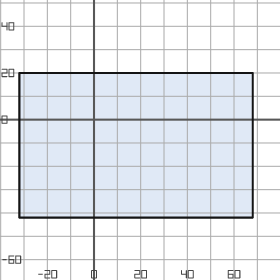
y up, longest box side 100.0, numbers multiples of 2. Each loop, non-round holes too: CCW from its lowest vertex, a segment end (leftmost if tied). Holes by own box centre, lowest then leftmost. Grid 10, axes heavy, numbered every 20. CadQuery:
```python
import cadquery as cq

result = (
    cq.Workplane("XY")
    .moveTo(-32.0, -42.0)
    .lineTo(68.0, -42.0)
    .lineTo(68.0, 20.0)
    .lineTo(-32.0, 20.0)
    .close()
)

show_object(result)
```